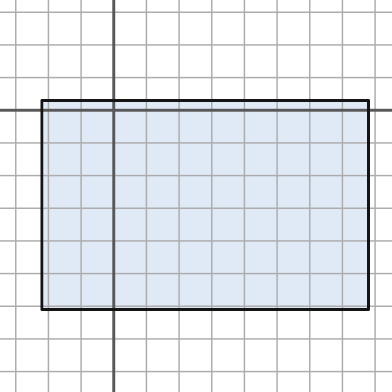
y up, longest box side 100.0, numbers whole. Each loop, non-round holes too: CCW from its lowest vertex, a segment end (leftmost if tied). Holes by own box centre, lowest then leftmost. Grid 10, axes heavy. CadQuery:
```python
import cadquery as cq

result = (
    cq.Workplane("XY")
    .moveTo(-22.0, -61.0)
    .lineTo(78.0, -61.0)
    .lineTo(78.0, 3.0)
    .lineTo(-22.0, 3.0)
    .close()
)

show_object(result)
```